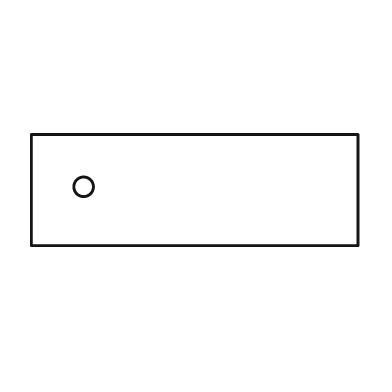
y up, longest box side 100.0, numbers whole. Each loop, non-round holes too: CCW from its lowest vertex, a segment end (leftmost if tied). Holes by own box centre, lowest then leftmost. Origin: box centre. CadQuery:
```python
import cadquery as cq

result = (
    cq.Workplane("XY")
    .moveTo(-50.0, -17.0)
    .lineTo(50.0, -17.0)
    .lineTo(50.0, 17.0)
    .lineTo(-50.0, 17.0)
    .close()
    .moveTo(-34.0, 1.0)
    .circle(3.0)
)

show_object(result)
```